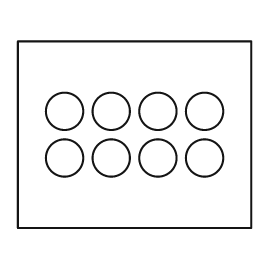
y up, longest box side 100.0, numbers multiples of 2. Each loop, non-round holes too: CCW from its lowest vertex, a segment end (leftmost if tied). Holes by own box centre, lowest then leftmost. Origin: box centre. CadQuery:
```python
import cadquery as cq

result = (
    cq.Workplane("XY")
    .moveTo(-50.0, -40.0)
    .lineTo(50.0, -40.0)
    .lineTo(50.0, 40.0)
    .lineTo(-50.0, 40.0)
    .close()
    .moveTo(-30.0, -10.0)
    .circle(8.0)
    .moveTo(-10.0, -10.0)
    .circle(8.0)
    .moveTo(10.0, -10.0)
    .circle(8.0)
    .moveTo(30.0, -10.0)
    .circle(8.0)
    .moveTo(-30.0, 10.0)
    .circle(8.0)
    .moveTo(-10.0, 10.0)
    .circle(8.0)
    .moveTo(10.0, 10.0)
    .circle(8.0)
    .moveTo(30.0, 10.0)
    .circle(8.0)
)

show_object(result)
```